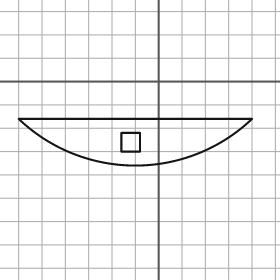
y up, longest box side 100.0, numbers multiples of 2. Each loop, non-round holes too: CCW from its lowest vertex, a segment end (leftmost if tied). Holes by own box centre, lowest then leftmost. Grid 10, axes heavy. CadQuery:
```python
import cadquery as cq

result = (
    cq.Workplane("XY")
    .moveTo(-60.0, -16.0)
    .threePointArc((-10.0, -36.0), (40.0, -16.0))
    .close()
    .moveTo(-16.0, -30.0)
    .lineTo(-8.0, -30.0)
    .lineTo(-8.0, -22.0)
    .lineTo(-16.0, -22.0)
    .close()
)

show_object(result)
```